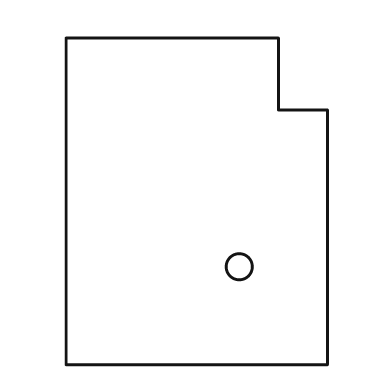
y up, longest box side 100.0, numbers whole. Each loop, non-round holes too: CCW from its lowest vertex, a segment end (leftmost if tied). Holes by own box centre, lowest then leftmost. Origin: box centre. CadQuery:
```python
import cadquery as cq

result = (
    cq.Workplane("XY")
    .moveTo(-40.0, -50.0)
    .lineTo(40.0, -50.0)
    .lineTo(40.0, 28.0)
    .lineTo(25.0, 28.0)
    .lineTo(25.0, 50.0)
    .lineTo(-40.0, 50.0)
    .close()
    .moveTo(13.0, -20.0)
    .circle(4.0)
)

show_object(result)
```